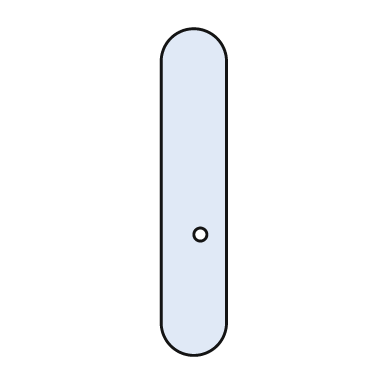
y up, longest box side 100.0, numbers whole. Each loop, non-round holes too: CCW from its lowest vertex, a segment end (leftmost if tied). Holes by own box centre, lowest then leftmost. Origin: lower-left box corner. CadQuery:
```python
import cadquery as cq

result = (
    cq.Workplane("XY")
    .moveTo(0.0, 10.0)
    .threePointArc((10.0, 0.0), (20.0, 10.0))
    .lineTo(20.0, 90.0)
    .threePointArc((10.0, 100.0), (0.0, 90.0))
    .close()
    .moveTo(12.0, 37.0)
    .circle(2.0)
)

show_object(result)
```